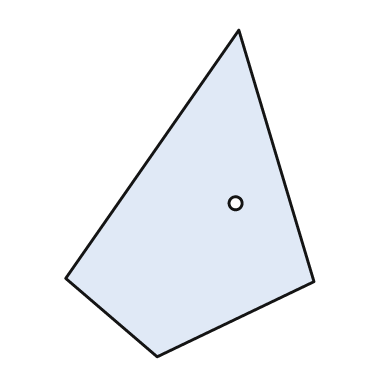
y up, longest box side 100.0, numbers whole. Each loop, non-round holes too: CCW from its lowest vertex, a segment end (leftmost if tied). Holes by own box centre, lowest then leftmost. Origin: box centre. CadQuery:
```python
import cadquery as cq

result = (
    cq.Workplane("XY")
    .moveTo(-10.0, -50.0)
    .lineTo(38.0, -27.0)
    .lineTo(15.0, 50.0)
    .lineTo(-38.0, -26.0)
    .close()
    .moveTo(14.0, -3.0)
    .circle(2.0)
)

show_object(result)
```